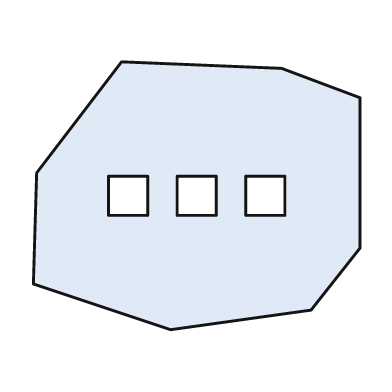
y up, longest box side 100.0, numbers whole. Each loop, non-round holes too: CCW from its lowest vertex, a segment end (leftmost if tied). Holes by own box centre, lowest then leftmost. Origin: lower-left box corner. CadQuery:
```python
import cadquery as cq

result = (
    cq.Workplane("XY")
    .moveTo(42.0, 0.0)
    .lineTo(85.0, 6.0)
    .lineTo(100.0, 25.0)
    .lineTo(100.0, 71.0)
    .lineTo(76.0, 80.0)
    .lineTo(27.0, 82.0)
    .lineTo(1.0, 48.0)
    .lineTo(0.0, 14.0)
    .close()
    .moveTo(23.0, 35.0)
    .lineTo(35.0, 35.0)
    .lineTo(35.0, 47.0)
    .lineTo(23.0, 47.0)
    .close()
    .moveTo(44.0, 35.0)
    .lineTo(56.0, 35.0)
    .lineTo(56.0, 47.0)
    .lineTo(44.0, 47.0)
    .close()
    .moveTo(65.0, 35.0)
    .lineTo(77.0, 35.0)
    .lineTo(77.0, 47.0)
    .lineTo(65.0, 47.0)
    .close()
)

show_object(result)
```